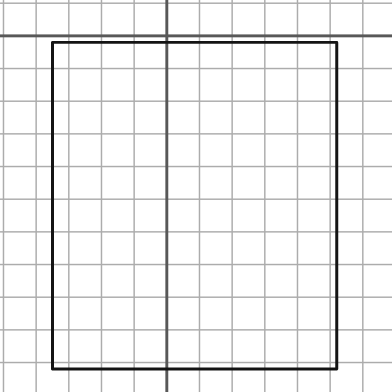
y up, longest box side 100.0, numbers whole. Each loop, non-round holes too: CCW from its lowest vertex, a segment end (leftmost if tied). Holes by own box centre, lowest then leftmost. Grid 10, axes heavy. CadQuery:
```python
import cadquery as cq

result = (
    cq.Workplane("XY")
    .moveTo(-35.0, -102.0)
    .lineTo(52.0, -102.0)
    .lineTo(52.0, -2.0)
    .lineTo(-35.0, -2.0)
    .close()
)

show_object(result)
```